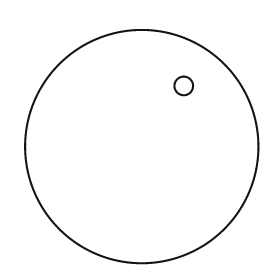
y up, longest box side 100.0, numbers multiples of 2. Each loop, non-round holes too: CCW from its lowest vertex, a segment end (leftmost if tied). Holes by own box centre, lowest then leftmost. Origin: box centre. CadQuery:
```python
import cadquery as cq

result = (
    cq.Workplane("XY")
    .moveTo(0.0, 0.0)
    .circle(50.0)
    .moveTo(18.0, 26.0)
    .circle(4.0)
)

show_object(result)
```